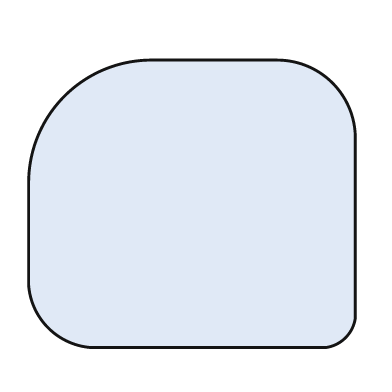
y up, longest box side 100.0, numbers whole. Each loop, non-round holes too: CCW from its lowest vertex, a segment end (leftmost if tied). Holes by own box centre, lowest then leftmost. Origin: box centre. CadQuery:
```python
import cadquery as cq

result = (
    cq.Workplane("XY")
    .moveTo(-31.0, -44.0)
    .lineTo(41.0, -44.0)
    .threePointArc((47.0, -41.0), (50.0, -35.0))
    .lineTo(50.0, 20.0)
    .threePointArc((43.0, 37.0), (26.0, 44.0))
    .lineTo(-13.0, 44.0)
    .threePointArc((-39.0, 33.0), (-50.0, 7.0))
    .lineTo(-50.0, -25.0)
    .threePointArc((-44.0, -38.0), (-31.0, -44.0))
    .close()
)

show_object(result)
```